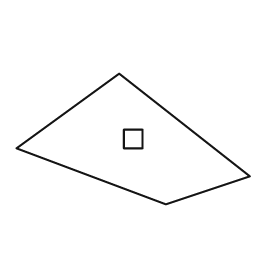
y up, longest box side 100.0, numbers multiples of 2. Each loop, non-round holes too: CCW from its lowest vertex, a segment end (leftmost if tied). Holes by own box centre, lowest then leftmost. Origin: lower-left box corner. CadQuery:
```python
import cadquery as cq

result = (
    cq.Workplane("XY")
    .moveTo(64.0, 0.0)
    .lineTo(100.0, 12.0)
    .lineTo(44.0, 56.0)
    .lineTo(0.0, 24.0)
    .close()
    .moveTo(46.0, 24.0)
    .lineTo(54.0, 24.0)
    .lineTo(54.0, 32.0)
    .lineTo(46.0, 32.0)
    .close()
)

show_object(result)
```